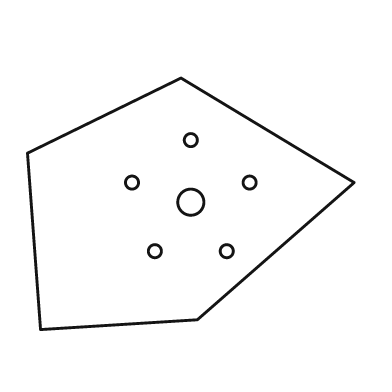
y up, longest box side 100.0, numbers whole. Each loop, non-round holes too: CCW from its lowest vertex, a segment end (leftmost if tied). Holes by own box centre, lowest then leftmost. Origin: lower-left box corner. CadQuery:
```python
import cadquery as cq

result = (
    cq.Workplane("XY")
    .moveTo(4.0, 0.0)
    .lineTo(52.0, 3.0)
    .lineTo(100.0, 45.0)
    .lineTo(47.0, 77.0)
    .lineTo(0.0, 54.0)
    .close()
    .moveTo(39.0, 24.0)
    .circle(2.0)
    .moveTo(61.0, 24.0)
    .circle(2.0)
    .moveTo(50.0, 39.0)
    .circle(4.0)
    .moveTo(32.0, 45.0)
    .circle(2.0)
    .moveTo(68.0, 45.0)
    .circle(2.0)
    .moveTo(50.0, 58.0)
    .circle(2.0)
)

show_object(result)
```